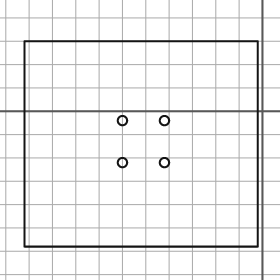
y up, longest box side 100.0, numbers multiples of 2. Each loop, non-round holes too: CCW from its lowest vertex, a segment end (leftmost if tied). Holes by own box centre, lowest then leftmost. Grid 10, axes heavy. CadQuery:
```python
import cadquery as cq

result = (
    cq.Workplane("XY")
    .moveTo(-102.0, -58.0)
    .lineTo(-2.0, -58.0)
    .lineTo(-2.0, 30.0)
    .lineTo(-102.0, 30.0)
    .close()
    .moveTo(-60.0, -22.0)
    .circle(2.0)
    .moveTo(-42.0, -22.0)
    .circle(2.0)
    .moveTo(-60.0, -4.0)
    .circle(2.0)
    .moveTo(-42.0, -4.0)
    .circle(2.0)
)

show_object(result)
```